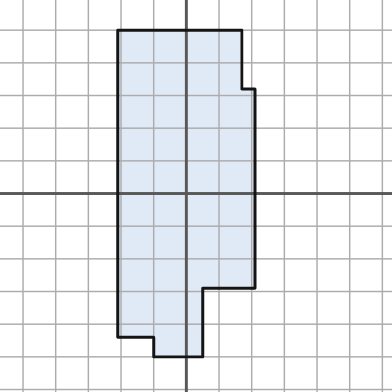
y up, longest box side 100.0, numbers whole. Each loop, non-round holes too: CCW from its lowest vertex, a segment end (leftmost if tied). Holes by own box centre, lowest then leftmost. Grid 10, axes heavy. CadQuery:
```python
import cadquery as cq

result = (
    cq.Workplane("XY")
    .moveTo(-10.0, -50.0)
    .lineTo(5.0, -50.0)
    .lineTo(5.0, -29.0)
    .lineTo(21.0, -29.0)
    .lineTo(21.0, 32.0)
    .lineTo(17.0, 32.0)
    .lineTo(17.0, 50.0)
    .lineTo(-21.0, 50.0)
    .lineTo(-21.0, -44.0)
    .lineTo(-10.0, -44.0)
    .close()
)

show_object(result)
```